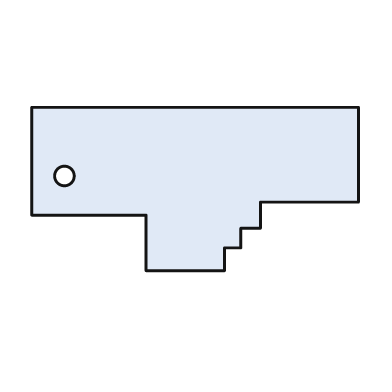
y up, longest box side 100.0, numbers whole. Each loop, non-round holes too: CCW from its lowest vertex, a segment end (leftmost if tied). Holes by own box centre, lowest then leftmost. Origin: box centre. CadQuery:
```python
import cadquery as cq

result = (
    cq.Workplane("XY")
    .moveTo(-15.0, -25.0)
    .lineTo(9.0, -25.0)
    .lineTo(9.0, -18.0)
    .lineTo(14.0, -18.0)
    .lineTo(14.0, -12.0)
    .lineTo(20.0, -12.0)
    .lineTo(20.0, -4.0)
    .lineTo(50.0, -4.0)
    .lineTo(50.0, 25.0)
    .lineTo(-50.0, 25.0)
    .lineTo(-50.0, -8.0)
    .lineTo(-15.0, -8.0)
    .close()
    .moveTo(-40.0, 4.0)
    .circle(3.0)
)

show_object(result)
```